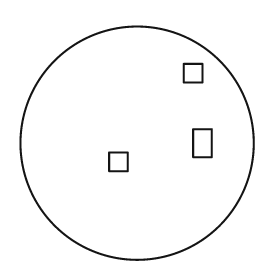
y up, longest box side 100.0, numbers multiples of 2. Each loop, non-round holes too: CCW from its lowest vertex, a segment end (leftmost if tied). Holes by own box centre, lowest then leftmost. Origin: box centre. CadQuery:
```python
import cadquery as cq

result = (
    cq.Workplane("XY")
    .moveTo(0.0, 0.0)
    .circle(50.0)
    .moveTo(-12.0, -12.0)
    .lineTo(-4.0, -12.0)
    .lineTo(-4.0, -4.0)
    .lineTo(-12.0, -4.0)
    .close()
    .moveTo(24.0, -6.0)
    .lineTo(32.0, -6.0)
    .lineTo(32.0, 6.0)
    .lineTo(24.0, 6.0)
    .close()
    .moveTo(20.0, 26.0)
    .lineTo(28.0, 26.0)
    .lineTo(28.0, 34.0)
    .lineTo(20.0, 34.0)
    .close()
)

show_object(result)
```